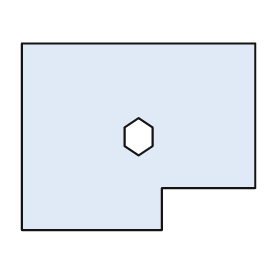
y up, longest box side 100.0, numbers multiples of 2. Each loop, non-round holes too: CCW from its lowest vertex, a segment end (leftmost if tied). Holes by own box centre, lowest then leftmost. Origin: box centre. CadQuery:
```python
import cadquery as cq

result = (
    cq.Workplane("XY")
    .moveTo(-50.0, -40.0)
    .lineTo(10.0, -40.0)
    .lineTo(10.0, -22.0)
    .lineTo(50.0, -22.0)
    .lineTo(50.0, 40.0)
    .lineTo(-50.0, 40.0)
    .close()
    .moveTo(0.0, -8.0)
    .lineTo(6.0, -4.0)
    .lineTo(6.0, 4.0)
    .lineTo(0.0, 8.0)
    .lineTo(-6.0, 4.0)
    .lineTo(-6.0, -4.0)
    .close()
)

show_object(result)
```